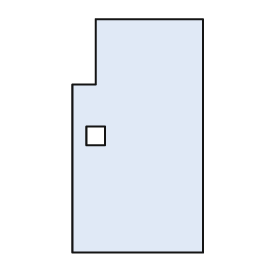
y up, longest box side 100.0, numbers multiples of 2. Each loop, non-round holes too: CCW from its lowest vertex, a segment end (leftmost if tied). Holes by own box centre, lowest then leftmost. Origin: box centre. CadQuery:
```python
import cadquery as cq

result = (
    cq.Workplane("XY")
    .moveTo(-28.0, -50.0)
    .lineTo(28.0, -50.0)
    .lineTo(28.0, 50.0)
    .lineTo(-18.0, 50.0)
    .lineTo(-18.0, 22.0)
    .lineTo(-28.0, 22.0)
    .close()
    .moveTo(-22.0, -4.0)
    .lineTo(-14.0, -4.0)
    .lineTo(-14.0, 4.0)
    .lineTo(-22.0, 4.0)
    .close()
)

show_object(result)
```